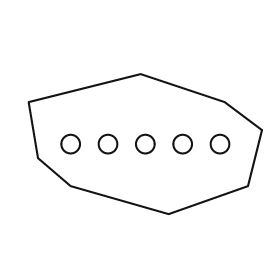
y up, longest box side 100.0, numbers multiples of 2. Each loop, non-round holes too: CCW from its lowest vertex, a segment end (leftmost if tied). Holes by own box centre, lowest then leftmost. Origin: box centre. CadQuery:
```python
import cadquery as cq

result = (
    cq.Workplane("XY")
    .moveTo(10.0, -30.0)
    .lineTo(44.0, -18.0)
    .lineTo(50.0, 6.0)
    .lineTo(34.0, 18.0)
    .lineTo(-2.0, 30.0)
    .lineTo(-50.0, 18.0)
    .lineTo(-46.0, -6.0)
    .lineTo(-32.0, -18.0)
    .close()
    .moveTo(-32.0, 0.0)
    .circle(4.0)
    .moveTo(-16.0, 0.0)
    .circle(4.0)
    .moveTo(0.0, 0.0)
    .circle(4.0)
    .moveTo(16.0, 0.0)
    .circle(4.0)
    .moveTo(32.0, 0.0)
    .circle(4.0)
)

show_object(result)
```